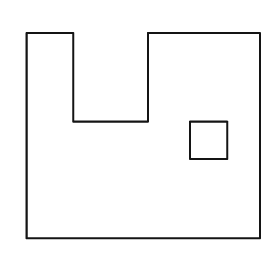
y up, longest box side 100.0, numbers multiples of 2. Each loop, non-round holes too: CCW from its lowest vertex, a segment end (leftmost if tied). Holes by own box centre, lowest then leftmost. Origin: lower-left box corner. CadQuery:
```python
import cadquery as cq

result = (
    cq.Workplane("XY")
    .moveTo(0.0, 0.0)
    .lineTo(100.0, 0.0)
    .lineTo(100.0, 88.0)
    .lineTo(52.0, 88.0)
    .lineTo(52.0, 50.0)
    .lineTo(20.0, 50.0)
    .lineTo(20.0, 88.0)
    .lineTo(0.0, 88.0)
    .close()
    .moveTo(70.0, 34.0)
    .lineTo(86.0, 34.0)
    .lineTo(86.0, 50.0)
    .lineTo(70.0, 50.0)
    .close()
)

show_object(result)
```